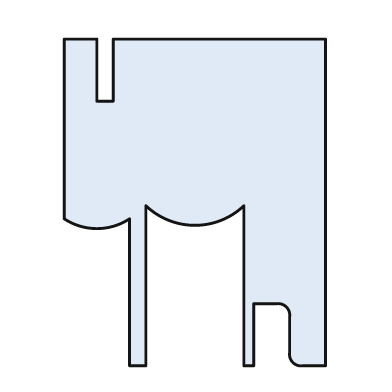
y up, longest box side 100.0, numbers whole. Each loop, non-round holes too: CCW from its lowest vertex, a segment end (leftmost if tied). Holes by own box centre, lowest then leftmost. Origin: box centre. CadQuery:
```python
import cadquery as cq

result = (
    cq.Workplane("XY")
    .moveTo(-20.0, -50.0)
    .lineTo(-15.0, -50.0)
    .lineTo(-15.0, -1.0)
    .threePointArc((0.0, -7.0), (15.0, -1.0))
    .lineTo(15.0, -50.0)
    .lineTo(18.0, -50.0)
    .lineTo(18.0, -31.0)
    .lineTo(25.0, -31.0)
    .threePointArc((28.0, -32.0), (29.0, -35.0))
    .lineTo(29.0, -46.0)
    .threePointArc((30.0, -49.0), (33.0, -50.0))
    .lineTo(40.0, -50.0)
    .lineTo(40.0, 50.0)
    .lineTo(-25.0, 50.0)
    .lineTo(-25.0, 31.0)
    .lineTo(-30.0, 31.0)
    .lineTo(-30.0, 50.0)
    .lineTo(-40.0, 50.0)
    .lineTo(-40.0, -5.0)
    .threePointArc((-30.0, -8.0), (-20.0, -5.0))
    .close()
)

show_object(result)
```